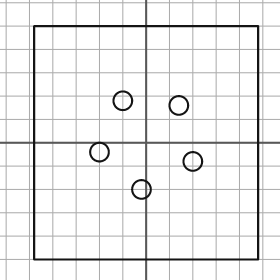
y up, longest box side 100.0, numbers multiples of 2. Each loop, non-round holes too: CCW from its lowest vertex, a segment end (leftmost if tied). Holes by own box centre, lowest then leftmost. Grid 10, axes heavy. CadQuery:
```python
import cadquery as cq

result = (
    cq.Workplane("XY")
    .moveTo(-48.0, -50.0)
    .lineTo(48.0, -50.0)
    .lineTo(48.0, 50.0)
    .lineTo(-48.0, 50.0)
    .close()
    .moveTo(-2.0, -20.0)
    .circle(4.0)
    .moveTo(20.0, -8.0)
    .circle(4.0)
    .moveTo(-20.0, -4.0)
    .circle(4.0)
    .moveTo(14.0, 16.0)
    .circle(4.0)
    .moveTo(-10.0, 18.0)
    .circle(4.0)
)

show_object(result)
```